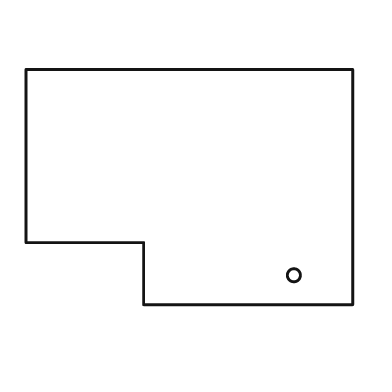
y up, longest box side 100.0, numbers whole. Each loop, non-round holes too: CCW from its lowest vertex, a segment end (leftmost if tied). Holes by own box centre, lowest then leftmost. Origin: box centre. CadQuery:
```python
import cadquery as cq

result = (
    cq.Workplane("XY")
    .moveTo(-14.0, -36.0)
    .lineTo(50.0, -36.0)
    .lineTo(50.0, 36.0)
    .lineTo(-50.0, 36.0)
    .lineTo(-50.0, -17.0)
    .lineTo(-14.0, -17.0)
    .close()
    .moveTo(32.0, -27.0)
    .circle(2.0)
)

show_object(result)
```